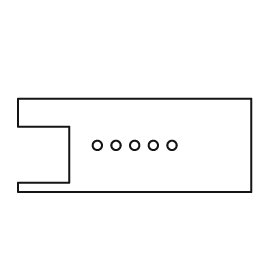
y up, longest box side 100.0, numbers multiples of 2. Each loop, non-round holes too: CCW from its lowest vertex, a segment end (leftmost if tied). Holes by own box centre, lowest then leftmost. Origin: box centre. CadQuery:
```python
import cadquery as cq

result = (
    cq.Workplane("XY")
    .moveTo(-50.0, -20.0)
    .lineTo(50.0, -20.0)
    .lineTo(50.0, 20.0)
    .lineTo(-50.0, 20.0)
    .lineTo(-50.0, 8.0)
    .lineTo(-28.0, 8.0)
    .lineTo(-28.0, -16.0)
    .lineTo(-50.0, -16.0)
    .close()
    .moveTo(-16.0, 0.0)
    .circle(2.0)
    .moveTo(-8.0, 0.0)
    .circle(2.0)
    .moveTo(0.0, 0.0)
    .circle(2.0)
    .moveTo(8.0, 0.0)
    .circle(2.0)
    .moveTo(16.0, 0.0)
    .circle(2.0)
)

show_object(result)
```